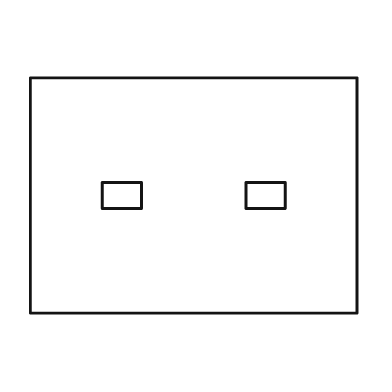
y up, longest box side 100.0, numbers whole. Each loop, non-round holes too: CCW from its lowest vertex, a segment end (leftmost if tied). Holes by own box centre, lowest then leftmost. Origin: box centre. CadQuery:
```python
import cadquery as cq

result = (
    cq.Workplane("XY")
    .moveTo(-50.0, -36.0)
    .lineTo(50.0, -36.0)
    .lineTo(50.0, 36.0)
    .lineTo(-50.0, 36.0)
    .close()
    .moveTo(-28.0, -4.0)
    .lineTo(-16.0, -4.0)
    .lineTo(-16.0, 4.0)
    .lineTo(-28.0, 4.0)
    .close()
    .moveTo(16.0, -4.0)
    .lineTo(28.0, -4.0)
    .lineTo(28.0, 4.0)
    .lineTo(16.0, 4.0)
    .close()
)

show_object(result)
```